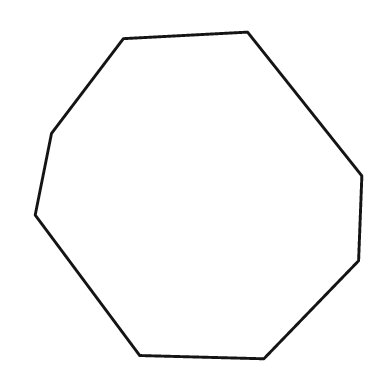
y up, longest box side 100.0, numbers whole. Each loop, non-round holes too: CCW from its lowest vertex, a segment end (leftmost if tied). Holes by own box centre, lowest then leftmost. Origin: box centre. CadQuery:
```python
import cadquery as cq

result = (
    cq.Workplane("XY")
    .moveTo(20.0, -50.0)
    .lineTo(49.0, -20.0)
    .lineTo(50.0, 6.0)
    .lineTo(15.0, 50.0)
    .lineTo(-23.0, 48.0)
    .lineTo(-45.0, 19.0)
    .lineTo(-50.0, -6.0)
    .lineTo(-18.0, -49.0)
    .close()
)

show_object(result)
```